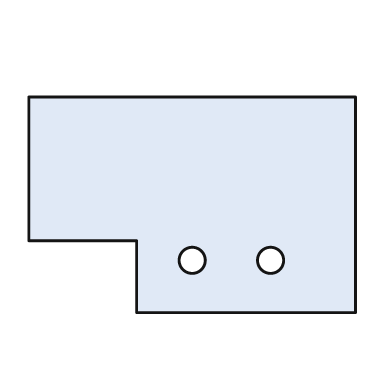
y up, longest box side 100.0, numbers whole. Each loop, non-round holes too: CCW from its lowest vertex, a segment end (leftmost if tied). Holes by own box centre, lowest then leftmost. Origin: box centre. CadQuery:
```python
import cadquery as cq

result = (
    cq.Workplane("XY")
    .moveTo(-17.0, -33.0)
    .lineTo(50.0, -33.0)
    .lineTo(50.0, 33.0)
    .lineTo(-50.0, 33.0)
    .lineTo(-50.0, -11.0)
    .lineTo(-17.0, -11.0)
    .close()
    .moveTo(0.0, -17.0)
    .circle(4.0)
    .moveTo(24.0, -17.0)
    .circle(4.0)
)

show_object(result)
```